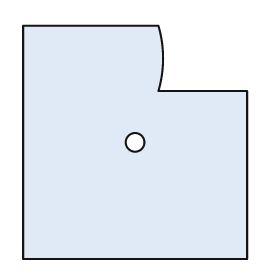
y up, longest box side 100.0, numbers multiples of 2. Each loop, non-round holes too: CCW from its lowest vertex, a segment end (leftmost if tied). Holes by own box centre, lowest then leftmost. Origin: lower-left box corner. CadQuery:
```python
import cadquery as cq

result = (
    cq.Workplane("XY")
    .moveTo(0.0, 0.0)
    .lineTo(96.0, 0.0)
    .lineTo(96.0, 72.0)
    .lineTo(58.0, 72.0)
    .threePointArc((60.0, 86.0), (58.0, 100.0))
    .lineTo(0.0, 100.0)
    .close()
    .moveTo(48.0, 50.0)
    .circle(4.0)
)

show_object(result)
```